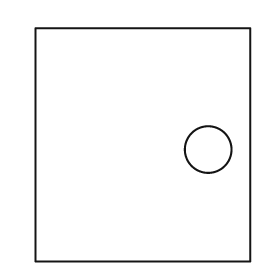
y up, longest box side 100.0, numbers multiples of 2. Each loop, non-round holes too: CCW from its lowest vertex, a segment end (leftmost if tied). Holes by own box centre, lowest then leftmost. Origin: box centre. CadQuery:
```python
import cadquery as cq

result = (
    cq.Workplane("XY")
    .moveTo(-46.0, -50.0)
    .lineTo(46.0, -50.0)
    .lineTo(46.0, 50.0)
    .lineTo(-46.0, 50.0)
    .close()
    .moveTo(28.0, -2.0)
    .circle(10.0)
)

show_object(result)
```